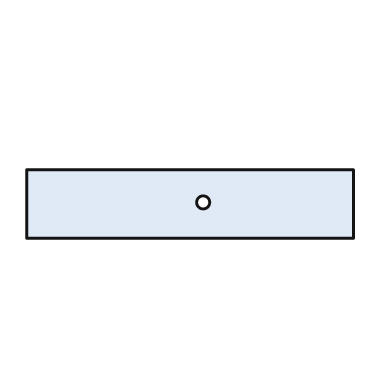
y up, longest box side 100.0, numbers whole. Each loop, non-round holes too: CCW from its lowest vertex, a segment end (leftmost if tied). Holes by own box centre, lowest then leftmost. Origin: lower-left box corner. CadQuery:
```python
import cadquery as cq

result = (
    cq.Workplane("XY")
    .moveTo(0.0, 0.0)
    .lineTo(100.0, 0.0)
    .lineTo(100.0, 21.0)
    .lineTo(0.0, 21.0)
    .close()
    .moveTo(54.0, 11.0)
    .circle(2.0)
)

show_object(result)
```